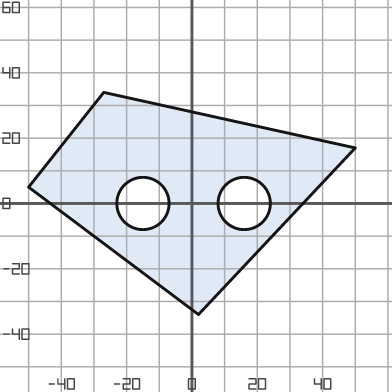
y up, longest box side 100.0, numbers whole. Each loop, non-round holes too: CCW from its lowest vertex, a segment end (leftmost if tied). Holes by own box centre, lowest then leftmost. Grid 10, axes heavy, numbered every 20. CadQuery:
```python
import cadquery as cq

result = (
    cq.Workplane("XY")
    .moveTo(2.0, -34.0)
    .lineTo(50.0, 17.0)
    .lineTo(-27.0, 34.0)
    .lineTo(-50.0, 5.0)
    .close()
    .moveTo(-15.0, 0.0)
    .circle(8.0)
    .moveTo(16.0, 0.0)
    .circle(8.0)
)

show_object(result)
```